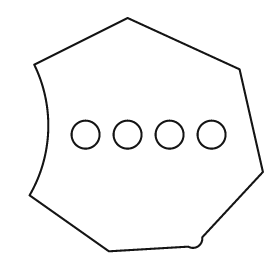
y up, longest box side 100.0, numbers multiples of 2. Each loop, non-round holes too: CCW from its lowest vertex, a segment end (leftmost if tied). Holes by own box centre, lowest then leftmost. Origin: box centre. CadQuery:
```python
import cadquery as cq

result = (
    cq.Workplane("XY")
    .moveTo(-16.0, -50.0)
    .lineTo(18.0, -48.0)
    .threePointArc((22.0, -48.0), (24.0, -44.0))
    .lineTo(50.0, -16.0)
    .lineTo(40.0, 28.0)
    .lineTo(-8.0, 50.0)
    .lineTo(-48.0, 30.0)
    .threePointArc((-42.0, 2.0), (-50.0, -26.0))
    .close()
    .moveTo(-26.0, 0.0)
    .circle(6.0)
    .moveTo(-8.0, 0.0)
    .circle(6.0)
    .moveTo(10.0, 0.0)
    .circle(6.0)
    .moveTo(28.0, 0.0)
    .circle(6.0)
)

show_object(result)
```